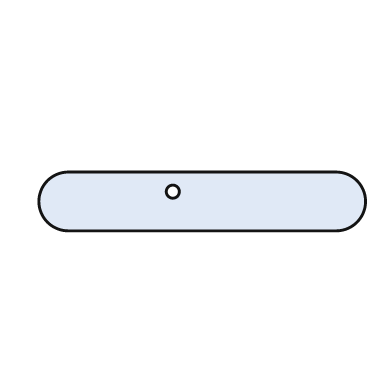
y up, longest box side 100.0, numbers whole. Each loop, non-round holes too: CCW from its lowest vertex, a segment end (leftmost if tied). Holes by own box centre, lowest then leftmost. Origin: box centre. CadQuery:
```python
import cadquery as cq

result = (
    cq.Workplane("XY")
    .moveTo(-41.0, -9.0)
    .lineTo(41.0, -9.0)
    .threePointArc((50.0, 0.0), (41.0, 9.0))
    .lineTo(-41.0, 9.0)
    .threePointArc((-50.0, 0.0), (-41.0, -9.0))
    .close()
    .moveTo(-9.0, 3.0)
    .circle(2.0)
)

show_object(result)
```